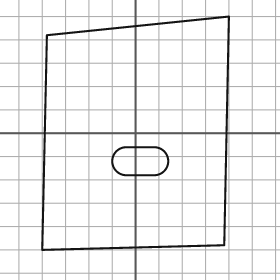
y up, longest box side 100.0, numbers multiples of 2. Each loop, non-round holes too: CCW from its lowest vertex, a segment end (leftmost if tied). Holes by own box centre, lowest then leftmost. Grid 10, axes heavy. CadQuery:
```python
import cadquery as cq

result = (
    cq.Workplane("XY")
    .moveTo(-40.0, -50.0)
    .lineTo(38.0, -48.0)
    .lineTo(40.0, 50.0)
    .lineTo(-38.0, 42.0)
    .close()
    .moveTo(-4.0, -18.0)
    .lineTo(8.0, -18.0)
    .threePointArc((14.0, -12.0), (8.0, -6.0))
    .lineTo(-4.0, -6.0)
    .threePointArc((-10.0, -12.0), (-4.0, -18.0))
    .close()
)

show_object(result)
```